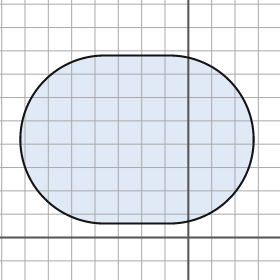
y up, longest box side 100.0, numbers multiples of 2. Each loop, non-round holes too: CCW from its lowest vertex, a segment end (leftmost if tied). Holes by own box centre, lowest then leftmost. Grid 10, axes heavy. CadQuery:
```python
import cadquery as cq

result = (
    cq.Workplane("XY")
    .moveTo(-36.0, 6.0)
    .lineTo(-8.0, 6.0)
    .threePointArc((28.0, 42.0), (-8.0, 78.0))
    .lineTo(-36.0, 78.0)
    .threePointArc((-72.0, 42.0), (-36.0, 6.0))
    .close()
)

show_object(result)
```